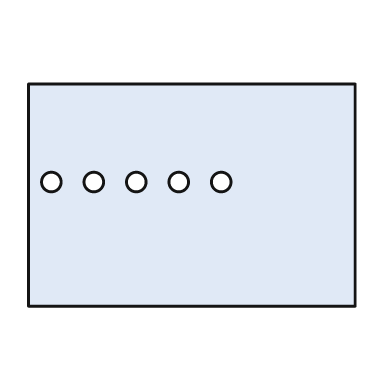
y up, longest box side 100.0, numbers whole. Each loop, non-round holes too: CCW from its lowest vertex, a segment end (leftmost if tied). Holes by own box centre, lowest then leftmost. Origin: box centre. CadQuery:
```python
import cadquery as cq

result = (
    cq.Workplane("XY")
    .moveTo(-50.0, -34.0)
    .lineTo(50.0, -34.0)
    .lineTo(50.0, 34.0)
    .lineTo(-50.0, 34.0)
    .close()
    .moveTo(-43.0, 4.0)
    .circle(3.0)
    .moveTo(-30.0, 4.0)
    .circle(3.0)
    .moveTo(-17.0, 4.0)
    .circle(3.0)
    .moveTo(-4.0, 4.0)
    .circle(3.0)
    .moveTo(9.0, 4.0)
    .circle(3.0)
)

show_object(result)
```